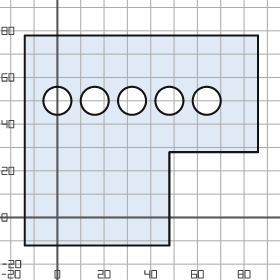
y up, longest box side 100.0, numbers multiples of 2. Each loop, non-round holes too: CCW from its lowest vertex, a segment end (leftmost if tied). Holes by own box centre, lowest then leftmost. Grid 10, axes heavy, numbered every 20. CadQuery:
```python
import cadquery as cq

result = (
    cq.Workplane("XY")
    .moveTo(-14.0, -12.0)
    .lineTo(48.0, -12.0)
    .lineTo(48.0, 28.0)
    .lineTo(86.0, 28.0)
    .lineTo(86.0, 78.0)
    .lineTo(-14.0, 78.0)
    .close()
    .moveTo(0.0, 50.0)
    .circle(6.0)
    .moveTo(16.0, 50.0)
    .circle(6.0)
    .moveTo(32.0, 50.0)
    .circle(6.0)
    .moveTo(48.0, 50.0)
    .circle(6.0)
    .moveTo(64.0, 50.0)
    .circle(6.0)
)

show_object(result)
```